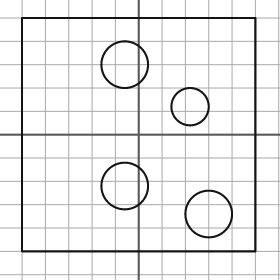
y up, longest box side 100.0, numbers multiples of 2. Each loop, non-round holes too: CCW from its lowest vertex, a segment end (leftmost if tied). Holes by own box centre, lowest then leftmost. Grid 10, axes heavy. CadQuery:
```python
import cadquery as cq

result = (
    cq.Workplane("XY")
    .moveTo(-50.0, -50.0)
    .lineTo(50.0, -50.0)
    .lineTo(50.0, 50.0)
    .lineTo(-50.0, 50.0)
    .close()
    .moveTo(30.0, -34.0)
    .circle(10.0)
    .moveTo(-6.0, -22.0)
    .circle(10.0)
    .moveTo(22.0, 12.0)
    .circle(8.0)
    .moveTo(-6.0, 30.0)
    .circle(10.0)
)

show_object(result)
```